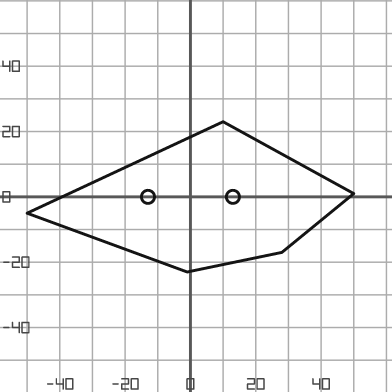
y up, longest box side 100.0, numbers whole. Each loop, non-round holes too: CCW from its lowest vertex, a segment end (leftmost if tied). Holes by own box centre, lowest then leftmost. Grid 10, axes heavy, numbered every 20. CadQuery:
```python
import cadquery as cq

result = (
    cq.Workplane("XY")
    .moveTo(-1.0, -23.0)
    .lineTo(28.0, -17.0)
    .lineTo(50.0, 1.0)
    .lineTo(10.0, 23.0)
    .lineTo(-50.0, -5.0)
    .close()
    .moveTo(-13.0, 0.0)
    .circle(2.0)
    .moveTo(13.0, 0.0)
    .circle(2.0)
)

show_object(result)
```